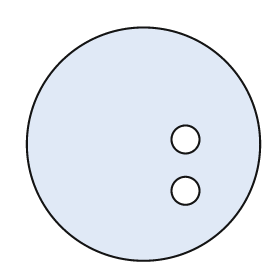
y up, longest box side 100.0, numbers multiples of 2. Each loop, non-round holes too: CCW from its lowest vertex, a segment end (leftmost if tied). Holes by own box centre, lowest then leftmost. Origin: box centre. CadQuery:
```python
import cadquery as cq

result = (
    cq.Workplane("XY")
    .moveTo(0.0, 0.0)
    .circle(50.0)
    .moveTo(18.0, -20.0)
    .circle(6.0)
    .moveTo(18.0, 2.0)
    .circle(6.0)
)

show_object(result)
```